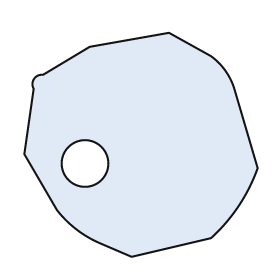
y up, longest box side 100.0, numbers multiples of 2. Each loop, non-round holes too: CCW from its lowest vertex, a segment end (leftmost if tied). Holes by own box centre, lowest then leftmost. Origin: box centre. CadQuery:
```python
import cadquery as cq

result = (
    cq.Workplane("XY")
    .moveTo(-4.0, -48.0)
    .lineTo(30.0, -40.0)
    .threePointArc((42.0, -26.0), (50.0, -10.0))
    .lineTo(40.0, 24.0)
    .threePointArc((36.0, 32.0), (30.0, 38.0))
    .lineTo(12.0, 48.0)
    .lineTo(-22.0, 42.0)
    .lineTo(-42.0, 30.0)
    .threePointArc((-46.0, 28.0), (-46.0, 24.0))
    .lineTo(-50.0, -4.0)
    .lineTo(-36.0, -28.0)
    .threePointArc((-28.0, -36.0), (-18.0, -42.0))
    .close()
    .moveTo(-24.0, -8.0)
    .circle(10.0)
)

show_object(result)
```